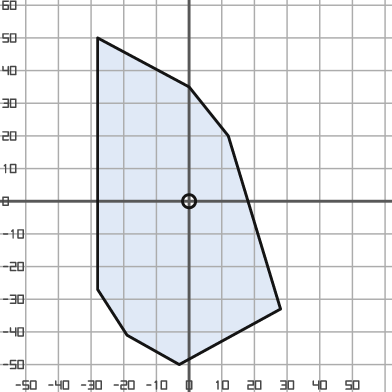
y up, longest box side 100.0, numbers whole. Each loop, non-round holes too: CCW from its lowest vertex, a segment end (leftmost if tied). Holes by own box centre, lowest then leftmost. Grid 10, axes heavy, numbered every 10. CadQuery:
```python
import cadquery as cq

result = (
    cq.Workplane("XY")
    .moveTo(-3.0, -50.0)
    .lineTo(28.0, -33.0)
    .lineTo(12.0, 20.0)
    .lineTo(0.0, 35.0)
    .lineTo(-28.0, 50.0)
    .lineTo(-28.0, -27.0)
    .lineTo(-19.0, -41.0)
    .close()
    .moveTo(0.0, 0.0)
    .circle(2.0)
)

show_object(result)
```